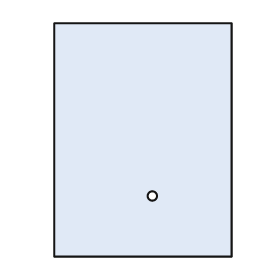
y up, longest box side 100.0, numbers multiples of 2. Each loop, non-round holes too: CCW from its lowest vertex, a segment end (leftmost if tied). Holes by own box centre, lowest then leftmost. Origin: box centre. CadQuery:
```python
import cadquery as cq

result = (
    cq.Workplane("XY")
    .moveTo(-38.0, -50.0)
    .lineTo(38.0, -50.0)
    .lineTo(38.0, 50.0)
    .lineTo(-38.0, 50.0)
    .close()
    .moveTo(4.0, -24.0)
    .circle(2.0)
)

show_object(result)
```